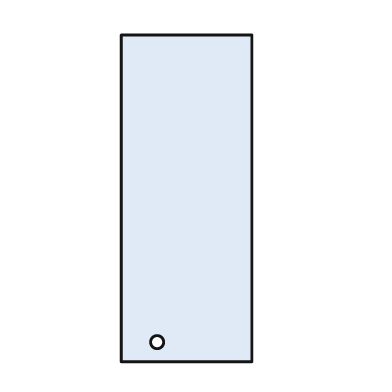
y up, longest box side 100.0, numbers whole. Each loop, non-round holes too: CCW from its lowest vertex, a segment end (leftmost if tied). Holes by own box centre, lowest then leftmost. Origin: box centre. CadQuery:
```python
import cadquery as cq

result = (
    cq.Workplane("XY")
    .moveTo(-20.0, -50.0)
    .lineTo(20.0, -50.0)
    .lineTo(20.0, 50.0)
    .lineTo(-20.0, 50.0)
    .close()
    .moveTo(-9.0, -44.0)
    .circle(2.0)
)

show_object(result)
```